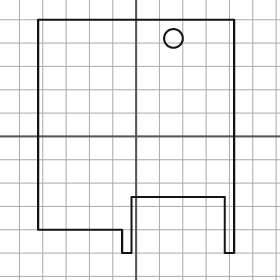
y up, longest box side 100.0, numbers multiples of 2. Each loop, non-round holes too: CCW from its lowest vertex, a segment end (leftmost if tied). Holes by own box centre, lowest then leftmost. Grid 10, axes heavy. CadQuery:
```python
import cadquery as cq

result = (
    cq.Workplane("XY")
    .moveTo(-6.0, -50.0)
    .lineTo(-2.0, -50.0)
    .lineTo(-2.0, -26.0)
    .lineTo(38.0, -26.0)
    .lineTo(38.0, -50.0)
    .lineTo(42.0, -50.0)
    .lineTo(42.0, 50.0)
    .lineTo(-42.0, 50.0)
    .lineTo(-42.0, -40.0)
    .lineTo(-6.0, -40.0)
    .close()
    .moveTo(16.0, 42.0)
    .circle(4.0)
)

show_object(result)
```